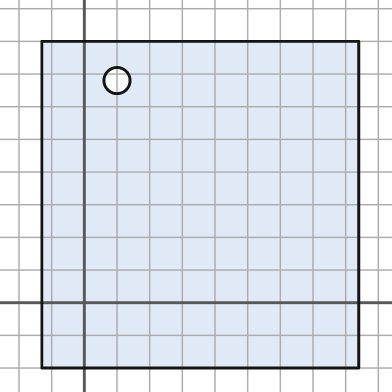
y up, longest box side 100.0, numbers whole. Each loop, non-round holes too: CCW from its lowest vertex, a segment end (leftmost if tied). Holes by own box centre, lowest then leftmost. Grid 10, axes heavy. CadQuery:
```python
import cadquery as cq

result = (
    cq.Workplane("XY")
    .moveTo(-13.0, -20.0)
    .lineTo(84.0, -20.0)
    .lineTo(84.0, 80.0)
    .lineTo(-13.0, 80.0)
    .close()
    .moveTo(10.0, 68.0)
    .circle(4.0)
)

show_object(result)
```